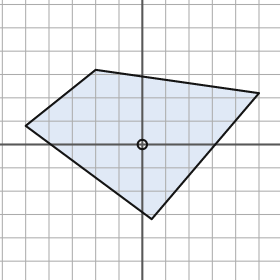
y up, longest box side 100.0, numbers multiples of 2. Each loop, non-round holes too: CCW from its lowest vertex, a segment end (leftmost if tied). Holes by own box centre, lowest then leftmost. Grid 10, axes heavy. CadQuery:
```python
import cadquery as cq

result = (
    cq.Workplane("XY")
    .moveTo(4.0, -32.0)
    .lineTo(50.0, 22.0)
    .lineTo(-20.0, 32.0)
    .lineTo(-50.0, 8.0)
    .close()
    .moveTo(0.0, 0.0)
    .circle(2.0)
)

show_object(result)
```